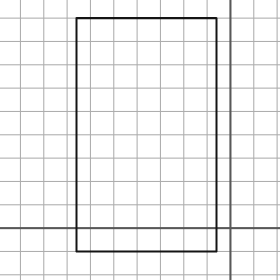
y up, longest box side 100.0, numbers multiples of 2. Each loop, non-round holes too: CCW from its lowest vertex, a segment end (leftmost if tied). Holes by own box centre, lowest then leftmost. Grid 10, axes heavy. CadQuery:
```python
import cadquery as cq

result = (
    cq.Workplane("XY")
    .moveTo(-66.0, -10.0)
    .lineTo(-6.0, -10.0)
    .lineTo(-6.0, 90.0)
    .lineTo(-66.0, 90.0)
    .close()
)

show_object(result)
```